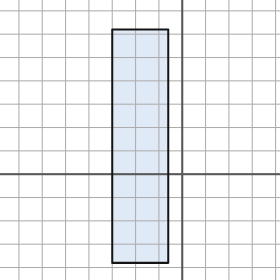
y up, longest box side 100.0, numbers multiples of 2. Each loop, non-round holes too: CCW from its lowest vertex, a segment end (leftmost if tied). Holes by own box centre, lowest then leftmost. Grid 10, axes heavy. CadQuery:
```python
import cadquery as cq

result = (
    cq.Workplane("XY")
    .moveTo(-30.0, -38.0)
    .lineTo(-6.0, -38.0)
    .lineTo(-6.0, 62.0)
    .lineTo(-30.0, 62.0)
    .close()
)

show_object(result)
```